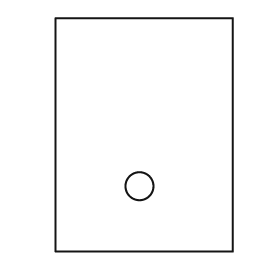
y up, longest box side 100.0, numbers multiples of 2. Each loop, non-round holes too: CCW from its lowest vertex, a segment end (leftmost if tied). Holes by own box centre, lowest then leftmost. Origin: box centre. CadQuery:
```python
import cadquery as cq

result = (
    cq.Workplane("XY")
    .moveTo(-38.0, -50.0)
    .lineTo(38.0, -50.0)
    .lineTo(38.0, 50.0)
    .lineTo(-38.0, 50.0)
    .close()
    .moveTo(-2.0, -22.0)
    .circle(6.0)
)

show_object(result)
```